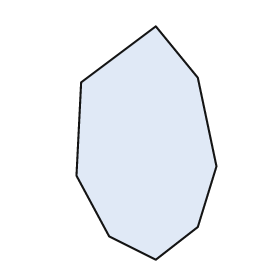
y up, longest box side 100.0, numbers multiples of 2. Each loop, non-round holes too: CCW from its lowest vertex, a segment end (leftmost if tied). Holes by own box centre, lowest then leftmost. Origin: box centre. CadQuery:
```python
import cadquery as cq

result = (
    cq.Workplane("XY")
    .moveTo(4.0, -50.0)
    .lineTo(22.0, -36.0)
    .lineTo(30.0, -10.0)
    .lineTo(22.0, 28.0)
    .lineTo(4.0, 50.0)
    .lineTo(-28.0, 26.0)
    .lineTo(-30.0, -14.0)
    .lineTo(-16.0, -40.0)
    .close()
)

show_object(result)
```